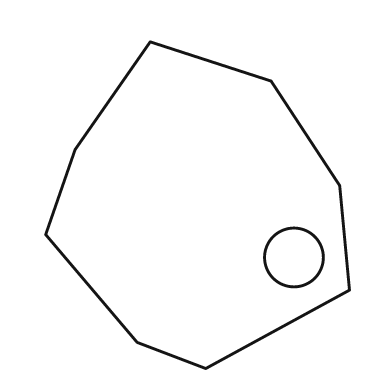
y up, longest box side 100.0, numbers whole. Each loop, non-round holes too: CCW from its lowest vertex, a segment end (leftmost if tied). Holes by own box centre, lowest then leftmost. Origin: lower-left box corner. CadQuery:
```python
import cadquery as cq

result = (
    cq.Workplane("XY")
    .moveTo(49.0, 0.0)
    .lineTo(93.0, 24.0)
    .lineTo(90.0, 56.0)
    .lineTo(69.0, 88.0)
    .lineTo(32.0, 100.0)
    .lineTo(9.0, 67.0)
    .lineTo(0.0, 41.0)
    .lineTo(28.0, 8.0)
    .close()
    .moveTo(76.0, 34.0)
    .circle(9.0)
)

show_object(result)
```